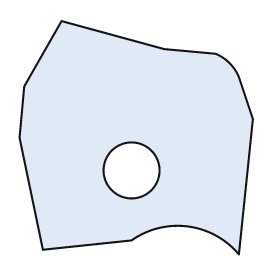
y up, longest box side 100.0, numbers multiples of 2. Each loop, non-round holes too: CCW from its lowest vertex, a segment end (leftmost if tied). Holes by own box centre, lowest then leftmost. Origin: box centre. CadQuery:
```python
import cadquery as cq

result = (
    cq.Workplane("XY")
    .moveTo(44.0, -50.0)
    .lineTo(50.0, 8.0)
    .lineTo(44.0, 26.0)
    .threePointArc((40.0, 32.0), (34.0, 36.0))
    .lineTo(12.0, 38.0)
    .lineTo(-32.0, 50.0)
    .lineTo(-48.0, 22.0)
    .lineTo(-50.0, 0.0)
    .lineTo(-40.0, -48.0)
    .lineTo(-2.0, -44.0)
    .threePointArc((22.0, -38.0), (44.0, -50.0))
    .close()
    .moveTo(-2.0, -14.0)
    .circle(12.0)
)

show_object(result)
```